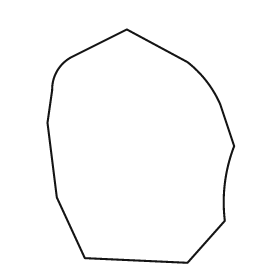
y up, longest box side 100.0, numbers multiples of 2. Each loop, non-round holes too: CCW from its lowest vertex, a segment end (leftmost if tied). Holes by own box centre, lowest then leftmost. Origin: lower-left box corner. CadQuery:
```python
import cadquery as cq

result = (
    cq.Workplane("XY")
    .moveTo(60.0, 0.0)
    .lineTo(76.0, 18.0)
    .threePointArc((76.0, 34.0), (80.0, 50.0))
    .lineTo(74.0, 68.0)
    .threePointArc((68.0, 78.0), (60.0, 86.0))
    .lineTo(34.0, 100.0)
    .lineTo(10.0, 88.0)
    .threePointArc((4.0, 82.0), (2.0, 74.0))
    .lineTo(0.0, 60.0)
    .lineTo(4.0, 28.0)
    .lineTo(16.0, 2.0)
    .close()
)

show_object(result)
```